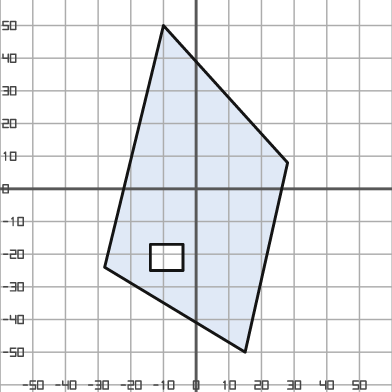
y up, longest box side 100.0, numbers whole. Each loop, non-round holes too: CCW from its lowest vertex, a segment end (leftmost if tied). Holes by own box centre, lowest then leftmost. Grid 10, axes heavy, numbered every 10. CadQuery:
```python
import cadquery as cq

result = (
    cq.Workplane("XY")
    .moveTo(15.0, -50.0)
    .lineTo(28.0, 8.0)
    .lineTo(-10.0, 50.0)
    .lineTo(-28.0, -24.0)
    .close()
    .moveTo(-14.0, -25.0)
    .lineTo(-4.0, -25.0)
    .lineTo(-4.0, -17.0)
    .lineTo(-14.0, -17.0)
    .close()
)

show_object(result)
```